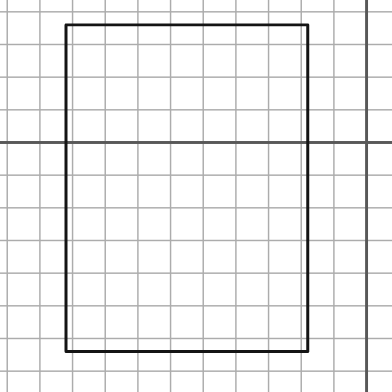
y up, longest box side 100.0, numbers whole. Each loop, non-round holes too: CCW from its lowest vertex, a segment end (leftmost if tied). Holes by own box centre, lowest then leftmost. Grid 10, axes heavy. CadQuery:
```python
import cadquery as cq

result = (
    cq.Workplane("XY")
    .moveTo(-92.0, -64.0)
    .lineTo(-18.0, -64.0)
    .lineTo(-18.0, 36.0)
    .lineTo(-92.0, 36.0)
    .close()
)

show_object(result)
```